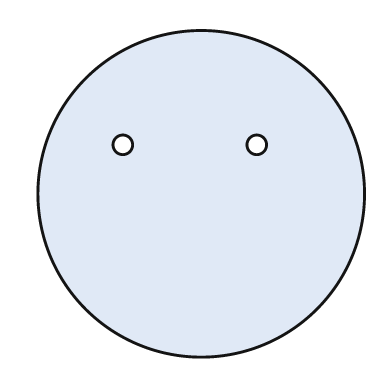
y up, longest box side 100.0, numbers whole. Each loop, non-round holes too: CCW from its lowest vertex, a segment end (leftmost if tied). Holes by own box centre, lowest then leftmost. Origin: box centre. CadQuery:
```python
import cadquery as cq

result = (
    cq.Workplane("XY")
    .moveTo(0.0, 0.0)
    .circle(50.0)
    .moveTo(-24.0, 15.0)
    .circle(3.0)
    .moveTo(17.0, 15.0)
    .circle(3.0)
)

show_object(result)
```